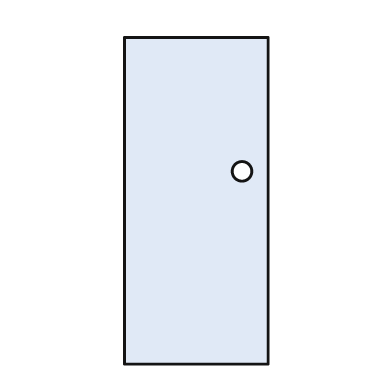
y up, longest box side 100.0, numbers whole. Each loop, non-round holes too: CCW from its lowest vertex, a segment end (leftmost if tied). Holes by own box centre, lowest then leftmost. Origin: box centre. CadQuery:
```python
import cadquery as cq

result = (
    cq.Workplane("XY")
    .moveTo(-22.0, -50.0)
    .lineTo(22.0, -50.0)
    .lineTo(22.0, 50.0)
    .lineTo(-22.0, 50.0)
    .close()
    .moveTo(14.0, 9.0)
    .circle(3.0)
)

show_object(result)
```